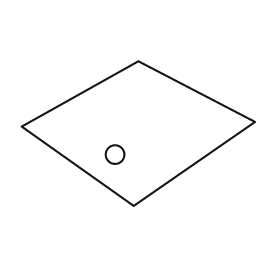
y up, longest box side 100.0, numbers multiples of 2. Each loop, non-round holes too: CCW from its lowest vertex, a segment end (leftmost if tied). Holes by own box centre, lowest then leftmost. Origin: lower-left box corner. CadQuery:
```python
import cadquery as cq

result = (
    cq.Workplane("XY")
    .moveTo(48.0, 0.0)
    .lineTo(100.0, 36.0)
    .lineTo(50.0, 62.0)
    .lineTo(0.0, 34.0)
    .close()
    .moveTo(40.0, 22.0)
    .circle(4.0)
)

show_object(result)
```